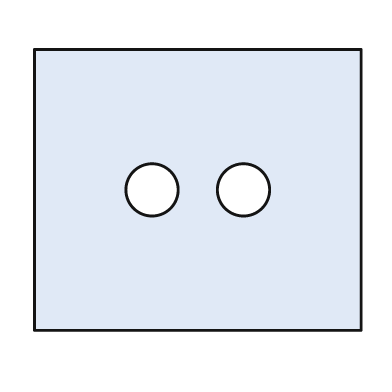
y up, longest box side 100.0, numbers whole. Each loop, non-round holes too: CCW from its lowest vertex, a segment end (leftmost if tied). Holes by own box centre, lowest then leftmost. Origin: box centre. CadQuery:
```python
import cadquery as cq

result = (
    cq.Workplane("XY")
    .moveTo(-50.0, -43.0)
    .lineTo(50.0, -43.0)
    .lineTo(50.0, 43.0)
    .lineTo(-50.0, 43.0)
    .close()
    .moveTo(-14.0, 0.0)
    .circle(8.0)
    .moveTo(14.0, 0.0)
    .circle(8.0)
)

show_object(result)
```